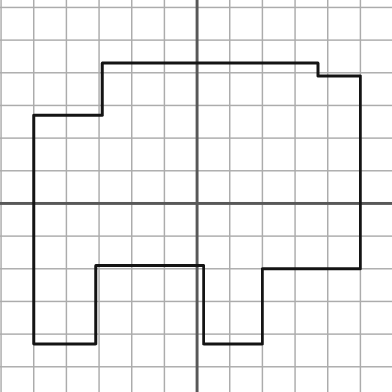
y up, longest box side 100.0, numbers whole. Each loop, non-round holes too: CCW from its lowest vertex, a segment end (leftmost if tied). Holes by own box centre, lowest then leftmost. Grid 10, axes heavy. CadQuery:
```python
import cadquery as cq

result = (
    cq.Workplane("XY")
    .moveTo(-50.0, -43.0)
    .lineTo(-31.0, -43.0)
    .lineTo(-31.0, -19.0)
    .lineTo(2.0, -19.0)
    .lineTo(2.0, -43.0)
    .lineTo(20.0, -43.0)
    .lineTo(20.0, -20.0)
    .lineTo(50.0, -20.0)
    .lineTo(50.0, 39.0)
    .lineTo(37.0, 39.0)
    .lineTo(37.0, 43.0)
    .lineTo(-29.0, 43.0)
    .lineTo(-29.0, 27.0)
    .lineTo(-50.0, 27.0)
    .close()
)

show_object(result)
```